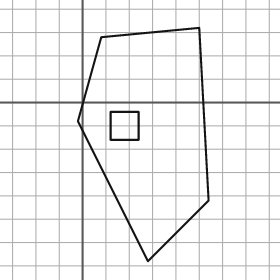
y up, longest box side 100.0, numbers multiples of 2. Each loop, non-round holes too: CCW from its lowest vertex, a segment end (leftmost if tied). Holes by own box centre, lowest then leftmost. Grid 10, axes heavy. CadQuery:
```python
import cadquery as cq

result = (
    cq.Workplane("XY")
    .moveTo(28.0, -68.0)
    .lineTo(54.0, -42.0)
    .lineTo(50.0, 32.0)
    .lineTo(8.0, 28.0)
    .lineTo(-2.0, -8.0)
    .close()
    .moveTo(12.0, -16.0)
    .lineTo(24.0, -16.0)
    .lineTo(24.0, -4.0)
    .lineTo(12.0, -4.0)
    .close()
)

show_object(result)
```